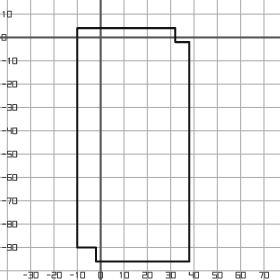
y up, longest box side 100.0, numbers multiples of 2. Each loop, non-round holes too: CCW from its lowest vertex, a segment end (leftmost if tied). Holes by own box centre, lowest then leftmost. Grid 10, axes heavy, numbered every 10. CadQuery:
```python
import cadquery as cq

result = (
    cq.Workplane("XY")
    .moveTo(-2.0, -96.0)
    .lineTo(38.0, -96.0)
    .lineTo(38.0, -2.0)
    .lineTo(32.0, -2.0)
    .lineTo(32.0, 4.0)
    .lineTo(-10.0, 4.0)
    .lineTo(-10.0, -90.0)
    .lineTo(-2.0, -90.0)
    .close()
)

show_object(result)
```